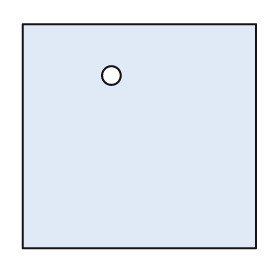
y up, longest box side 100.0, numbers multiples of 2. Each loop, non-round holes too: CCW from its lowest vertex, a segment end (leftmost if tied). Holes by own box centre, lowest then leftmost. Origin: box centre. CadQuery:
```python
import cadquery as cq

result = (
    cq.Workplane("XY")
    .moveTo(-50.0, -48.0)
    .lineTo(50.0, -48.0)
    .lineTo(50.0, 48.0)
    .lineTo(-50.0, 48.0)
    .close()
    .moveTo(-12.0, 26.0)
    .circle(4.0)
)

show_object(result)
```